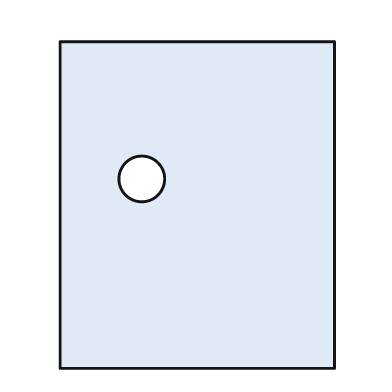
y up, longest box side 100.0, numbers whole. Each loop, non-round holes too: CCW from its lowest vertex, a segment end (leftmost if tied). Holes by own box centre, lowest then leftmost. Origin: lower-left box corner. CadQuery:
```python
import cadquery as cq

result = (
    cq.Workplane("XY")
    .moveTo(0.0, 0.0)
    .lineTo(84.0, 0.0)
    .lineTo(84.0, 100.0)
    .lineTo(0.0, 100.0)
    .close()
    .moveTo(25.0, 58.0)
    .circle(7.0)
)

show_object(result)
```